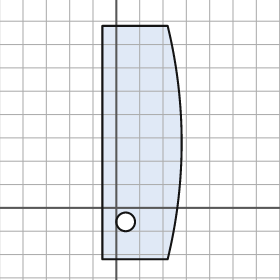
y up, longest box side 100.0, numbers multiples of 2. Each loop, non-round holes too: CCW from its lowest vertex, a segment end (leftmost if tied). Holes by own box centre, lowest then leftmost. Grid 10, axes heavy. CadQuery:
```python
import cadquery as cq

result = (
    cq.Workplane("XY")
    .moveTo(-6.0, -22.0)
    .lineTo(22.0, -22.0)
    .threePointArc((28.0, 28.0), (22.0, 78.0))
    .lineTo(-6.0, 78.0)
    .close()
    .moveTo(4.0, -6.0)
    .circle(4.0)
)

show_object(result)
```